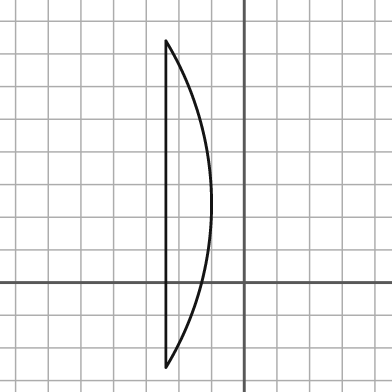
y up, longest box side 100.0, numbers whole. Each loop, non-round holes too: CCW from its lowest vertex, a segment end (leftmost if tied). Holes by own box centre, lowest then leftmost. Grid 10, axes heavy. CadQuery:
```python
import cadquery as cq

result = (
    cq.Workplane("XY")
    .moveTo(-24.0, -26.0)
    .threePointArc((-10.0, 24.0), (-24.0, 74.0))
    .close()
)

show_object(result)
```